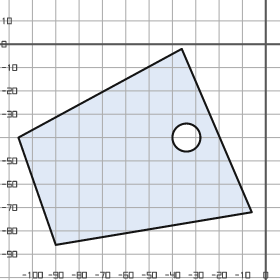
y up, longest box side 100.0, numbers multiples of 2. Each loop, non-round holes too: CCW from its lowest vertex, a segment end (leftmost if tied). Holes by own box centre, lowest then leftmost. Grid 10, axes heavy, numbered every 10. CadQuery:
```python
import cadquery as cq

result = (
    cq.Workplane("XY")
    .moveTo(-90.0, -86.0)
    .lineTo(-6.0, -72.0)
    .lineTo(-36.0, -2.0)
    .lineTo(-106.0, -40.0)
    .close()
    .moveTo(-34.0, -40.0)
    .circle(6.0)
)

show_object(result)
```